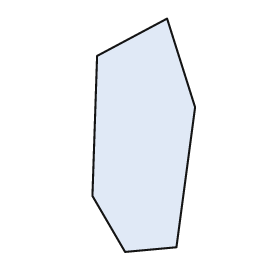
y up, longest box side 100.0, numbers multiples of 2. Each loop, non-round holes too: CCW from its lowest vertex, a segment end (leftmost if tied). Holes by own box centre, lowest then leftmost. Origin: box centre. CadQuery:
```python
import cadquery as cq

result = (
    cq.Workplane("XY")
    .moveTo(-8.0, -50.0)
    .lineTo(14.0, -48.0)
    .lineTo(22.0, 12.0)
    .lineTo(10.0, 50.0)
    .lineTo(-20.0, 34.0)
    .lineTo(-22.0, -26.0)
    .close()
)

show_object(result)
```